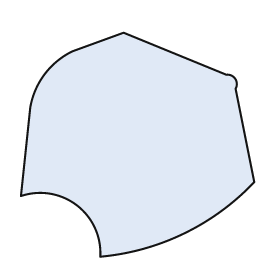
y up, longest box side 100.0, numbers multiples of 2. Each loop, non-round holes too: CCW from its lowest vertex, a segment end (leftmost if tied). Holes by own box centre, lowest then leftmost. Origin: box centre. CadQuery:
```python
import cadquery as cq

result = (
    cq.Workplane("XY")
    .moveTo(-16.0, -48.0)
    .threePointArc((20.0, -38.0), (50.0, -16.0))
    .lineTo(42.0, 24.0)
    .threePointArc((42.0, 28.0), (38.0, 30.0))
    .lineTo(-6.0, 48.0)
    .lineTo(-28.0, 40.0)
    .threePointArc((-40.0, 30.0), (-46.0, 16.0))
    .lineTo(-50.0, -22.0)
    .threePointArc((-26.0, -26.0), (-16.0, -48.0))
    .close()
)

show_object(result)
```